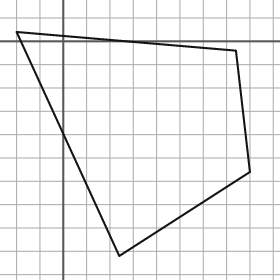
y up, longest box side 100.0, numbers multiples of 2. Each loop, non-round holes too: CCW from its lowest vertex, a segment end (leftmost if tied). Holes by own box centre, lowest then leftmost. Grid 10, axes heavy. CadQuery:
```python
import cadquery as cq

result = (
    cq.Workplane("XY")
    .moveTo(24.0, -92.0)
    .lineTo(80.0, -56.0)
    .lineTo(74.0, -4.0)
    .lineTo(-20.0, 4.0)
    .close()
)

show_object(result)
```